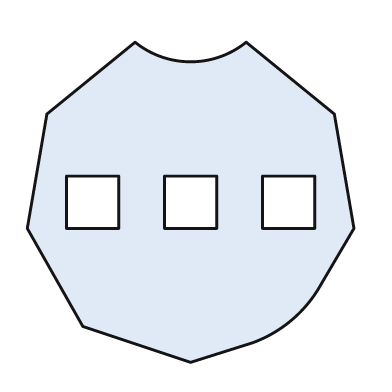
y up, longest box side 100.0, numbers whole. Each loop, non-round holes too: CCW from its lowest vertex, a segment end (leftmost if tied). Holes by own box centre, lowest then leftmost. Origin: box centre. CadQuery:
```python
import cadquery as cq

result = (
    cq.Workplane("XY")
    .moveTo(0.0, -49.0)
    .lineTo(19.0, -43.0)
    .threePointArc((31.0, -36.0), (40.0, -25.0))
    .lineTo(50.0, -8.0)
    .lineTo(44.0, 27.0)
    .lineTo(17.0, 49.0)
    .threePointArc((0.0, 43.0), (-17.0, 49.0))
    .lineTo(-44.0, 27.0)
    .lineTo(-50.0, -8.0)
    .lineTo(-33.0, -38.0)
    .close()
    .moveTo(-38.0, -8.0)
    .lineTo(-22.0, -8.0)
    .lineTo(-22.0, 8.0)
    .lineTo(-38.0, 8.0)
    .close()
    .moveTo(-8.0, -8.0)
    .lineTo(8.0, -8.0)
    .lineTo(8.0, 8.0)
    .lineTo(-8.0, 8.0)
    .close()
    .moveTo(22.0, -8.0)
    .lineTo(38.0, -8.0)
    .lineTo(38.0, 8.0)
    .lineTo(22.0, 8.0)
    .close()
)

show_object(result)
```